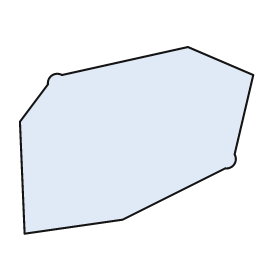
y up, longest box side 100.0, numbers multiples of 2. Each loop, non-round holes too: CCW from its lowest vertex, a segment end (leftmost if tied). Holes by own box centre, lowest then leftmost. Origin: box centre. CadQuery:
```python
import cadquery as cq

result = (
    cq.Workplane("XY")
    .moveTo(-48.0, -40.0)
    .lineTo(-6.0, -34.0)
    .lineTo(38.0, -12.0)
    .threePointArc((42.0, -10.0), (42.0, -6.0))
    .lineTo(50.0, 28.0)
    .lineTo(22.0, 40.0)
    .lineTo(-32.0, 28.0)
    .threePointArc((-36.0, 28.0), (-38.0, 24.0))
    .lineTo(-50.0, 8.0)
    .close()
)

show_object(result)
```